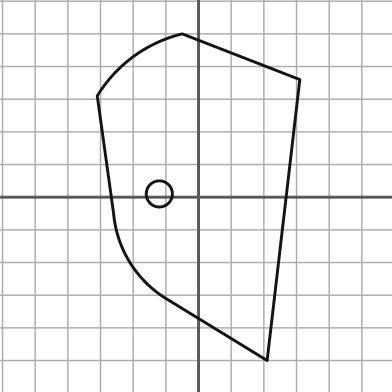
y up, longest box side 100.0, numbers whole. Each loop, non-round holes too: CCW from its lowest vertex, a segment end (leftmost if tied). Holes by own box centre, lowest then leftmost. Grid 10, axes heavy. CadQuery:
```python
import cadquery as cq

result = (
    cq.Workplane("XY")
    .moveTo(21.0, -50.0)
    .lineTo(31.0, 36.0)
    .lineTo(-5.0, 50.0)
    .threePointArc((-20.0, 43.0), (-31.0, 31.0))
    .lineTo(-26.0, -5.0)
    .threePointArc((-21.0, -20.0), (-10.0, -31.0))
    .close()
    .moveTo(-12.0, 1.0)
    .circle(4.0)
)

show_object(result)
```